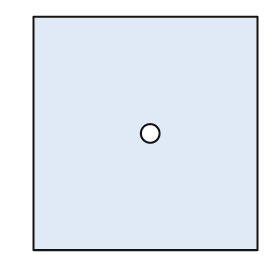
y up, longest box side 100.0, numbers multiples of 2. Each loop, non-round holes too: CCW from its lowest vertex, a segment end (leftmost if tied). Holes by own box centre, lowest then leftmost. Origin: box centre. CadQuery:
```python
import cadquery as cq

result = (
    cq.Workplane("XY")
    .moveTo(-48.0, -50.0)
    .lineTo(48.0, -50.0)
    .lineTo(48.0, 50.0)
    .lineTo(-48.0, 50.0)
    .close()
    .moveTo(2.0, 0.0)
    .circle(4.0)
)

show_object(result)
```